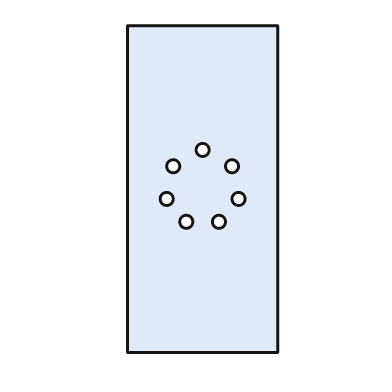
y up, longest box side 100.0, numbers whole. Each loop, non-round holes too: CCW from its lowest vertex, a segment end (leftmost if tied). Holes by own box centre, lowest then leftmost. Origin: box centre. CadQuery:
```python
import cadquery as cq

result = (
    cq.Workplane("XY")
    .moveTo(-23.0, -50.0)
    .lineTo(23.0, -50.0)
    .lineTo(23.0, 50.0)
    .lineTo(-23.0, 50.0)
    .close()
    .moveTo(-5.0, -10.0)
    .circle(2.0)
    .moveTo(5.0, -10.0)
    .circle(2.0)
    .moveTo(-11.0, -3.0)
    .circle(2.0)
    .moveTo(11.0, -3.0)
    .circle(2.0)
    .moveTo(-9.0, 7.0)
    .circle(2.0)
    .moveTo(9.0, 7.0)
    .circle(2.0)
    .moveTo(0.0, 12.0)
    .circle(2.0)
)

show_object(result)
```